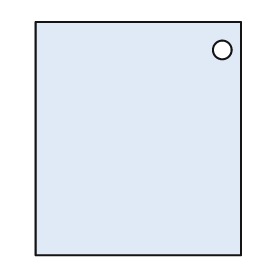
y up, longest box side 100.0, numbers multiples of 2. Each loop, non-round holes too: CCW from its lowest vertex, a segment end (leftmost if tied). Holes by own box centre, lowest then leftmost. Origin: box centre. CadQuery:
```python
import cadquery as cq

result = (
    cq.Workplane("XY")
    .moveTo(-44.0, -50.0)
    .lineTo(44.0, -50.0)
    .lineTo(44.0, 50.0)
    .lineTo(-44.0, 50.0)
    .close()
    .moveTo(36.0, 38.0)
    .circle(4.0)
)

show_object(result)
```